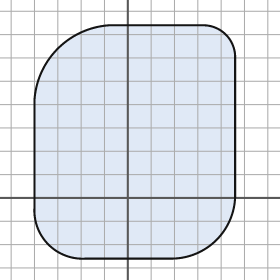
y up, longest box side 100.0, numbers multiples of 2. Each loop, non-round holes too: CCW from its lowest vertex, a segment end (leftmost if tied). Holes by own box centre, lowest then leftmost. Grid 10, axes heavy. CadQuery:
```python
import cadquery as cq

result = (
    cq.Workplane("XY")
    .moveTo(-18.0, -26.0)
    .lineTo(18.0, -26.0)
    .threePointArc((38.0, -18.0), (46.0, 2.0))
    .lineTo(46.0, 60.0)
    .threePointArc((42.0, 70.0), (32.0, 74.0))
    .lineTo(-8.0, 74.0)
    .threePointArc((-30.0, 64.0), (-40.0, 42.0))
    .lineTo(-40.0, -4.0)
    .threePointArc((-34.0, -20.0), (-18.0, -26.0))
    .close()
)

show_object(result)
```